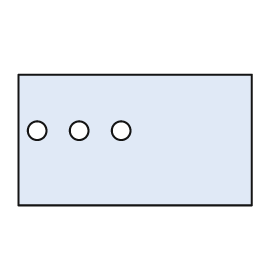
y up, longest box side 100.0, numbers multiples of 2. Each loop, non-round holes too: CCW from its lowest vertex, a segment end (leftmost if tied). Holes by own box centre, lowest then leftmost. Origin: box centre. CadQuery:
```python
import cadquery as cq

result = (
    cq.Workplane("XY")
    .moveTo(-50.0, -28.0)
    .lineTo(50.0, -28.0)
    .lineTo(50.0, 28.0)
    .lineTo(-50.0, 28.0)
    .close()
    .moveTo(-42.0, 4.0)
    .circle(4.0)
    .moveTo(-24.0, 4.0)
    .circle(4.0)
    .moveTo(-6.0, 4.0)
    .circle(4.0)
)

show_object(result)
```